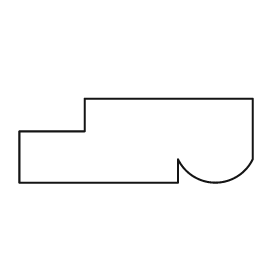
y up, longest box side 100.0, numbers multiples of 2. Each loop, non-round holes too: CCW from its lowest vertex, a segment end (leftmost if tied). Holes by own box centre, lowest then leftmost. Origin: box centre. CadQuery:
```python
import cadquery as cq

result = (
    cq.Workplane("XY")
    .moveTo(-50.0, -18.0)
    .lineTo(18.0, -18.0)
    .lineTo(18.0, -8.0)
    .threePointArc((34.0, -18.0), (50.0, -8.0))
    .lineTo(50.0, 18.0)
    .lineTo(-22.0, 18.0)
    .lineTo(-22.0, 4.0)
    .lineTo(-50.0, 4.0)
    .close()
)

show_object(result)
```